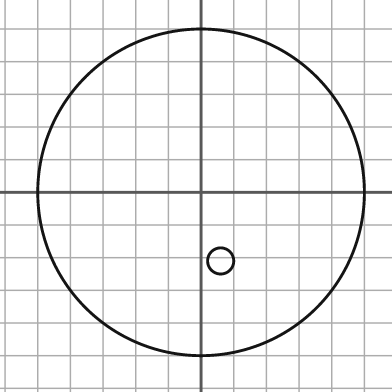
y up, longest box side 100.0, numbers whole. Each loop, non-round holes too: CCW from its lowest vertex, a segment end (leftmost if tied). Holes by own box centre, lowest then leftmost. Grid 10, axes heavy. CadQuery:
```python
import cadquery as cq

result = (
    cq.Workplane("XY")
    .moveTo(0.0, 0.0)
    .circle(50.0)
    .moveTo(6.0, -21.0)
    .circle(4.0)
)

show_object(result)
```